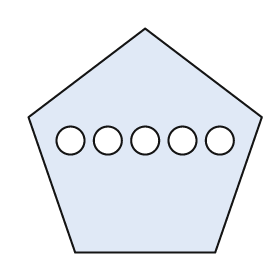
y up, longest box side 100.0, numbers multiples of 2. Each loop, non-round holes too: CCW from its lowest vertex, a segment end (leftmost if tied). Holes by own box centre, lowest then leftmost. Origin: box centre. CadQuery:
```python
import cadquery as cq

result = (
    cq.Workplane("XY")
    .moveTo(-30.0, -48.0)
    .lineTo(30.0, -48.0)
    .lineTo(50.0, 10.0)
    .lineTo(0.0, 48.0)
    .lineTo(-50.0, 10.0)
    .close()
    .moveTo(-32.0, 0.0)
    .circle(6.0)
    .moveTo(-16.0, 0.0)
    .circle(6.0)
    .moveTo(0.0, 0.0)
    .circle(6.0)
    .moveTo(16.0, 0.0)
    .circle(6.0)
    .moveTo(32.0, 0.0)
    .circle(6.0)
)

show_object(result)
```